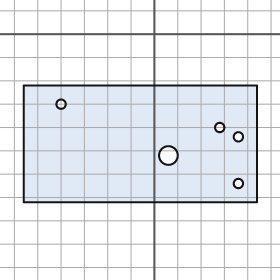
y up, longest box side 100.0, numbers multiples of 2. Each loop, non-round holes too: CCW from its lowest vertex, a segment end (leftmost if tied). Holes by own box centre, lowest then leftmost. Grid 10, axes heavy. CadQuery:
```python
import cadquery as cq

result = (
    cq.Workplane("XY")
    .moveTo(-56.0, -72.0)
    .lineTo(44.0, -72.0)
    .lineTo(44.0, -22.0)
    .lineTo(-56.0, -22.0)
    .close()
    .moveTo(36.0, -64.0)
    .circle(2.0)
    .moveTo(6.0, -52.0)
    .circle(4.0)
    .moveTo(36.0, -44.0)
    .circle(2.0)
    .moveTo(28.0, -40.0)
    .circle(2.0)
    .moveTo(-40.0, -30.0)
    .circle(2.0)
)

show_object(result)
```